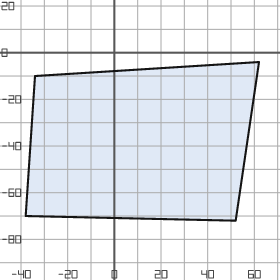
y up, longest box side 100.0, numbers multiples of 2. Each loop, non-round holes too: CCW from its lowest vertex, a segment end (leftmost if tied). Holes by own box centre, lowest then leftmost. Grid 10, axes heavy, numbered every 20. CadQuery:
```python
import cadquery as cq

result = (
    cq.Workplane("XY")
    .moveTo(52.0, -72.0)
    .lineTo(62.0, -4.0)
    .lineTo(-34.0, -10.0)
    .lineTo(-38.0, -70.0)
    .close()
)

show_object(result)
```